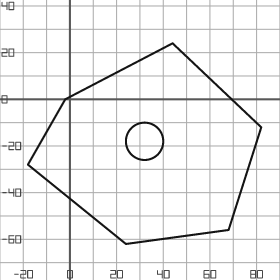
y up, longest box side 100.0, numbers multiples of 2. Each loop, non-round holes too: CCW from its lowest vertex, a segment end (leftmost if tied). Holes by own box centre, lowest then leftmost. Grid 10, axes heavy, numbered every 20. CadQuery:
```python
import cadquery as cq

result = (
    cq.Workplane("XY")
    .moveTo(24.0, -62.0)
    .lineTo(68.0, -56.0)
    .lineTo(82.0, -12.0)
    .lineTo(44.0, 24.0)
    .lineTo(-2.0, 0.0)
    .lineTo(-18.0, -28.0)
    .close()
    .moveTo(32.0, -18.0)
    .circle(8.0)
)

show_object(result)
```